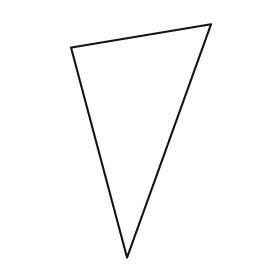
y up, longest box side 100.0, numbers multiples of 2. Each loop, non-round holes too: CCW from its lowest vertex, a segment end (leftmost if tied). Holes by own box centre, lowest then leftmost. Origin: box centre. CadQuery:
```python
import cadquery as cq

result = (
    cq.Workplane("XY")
    .moveTo(-6.0, -50.0)
    .lineTo(30.0, 50.0)
    .lineTo(-30.0, 40.0)
    .close()
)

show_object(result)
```